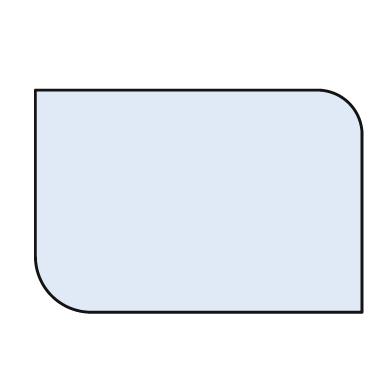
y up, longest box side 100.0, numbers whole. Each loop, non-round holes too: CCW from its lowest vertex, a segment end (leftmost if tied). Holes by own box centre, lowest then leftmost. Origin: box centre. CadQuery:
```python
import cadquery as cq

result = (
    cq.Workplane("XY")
    .moveTo(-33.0, -34.0)
    .lineTo(50.0, -34.0)
    .lineTo(50.0, 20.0)
    .threePointArc((46.0, 30.0), (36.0, 34.0))
    .lineTo(-50.0, 34.0)
    .lineTo(-50.0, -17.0)
    .threePointArc((-45.0, -29.0), (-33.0, -34.0))
    .close()
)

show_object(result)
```